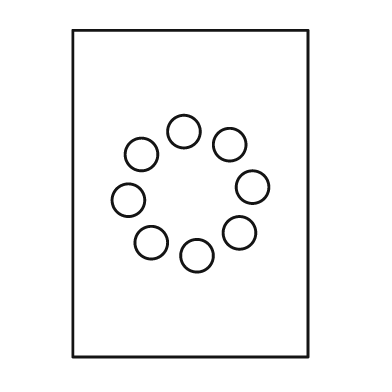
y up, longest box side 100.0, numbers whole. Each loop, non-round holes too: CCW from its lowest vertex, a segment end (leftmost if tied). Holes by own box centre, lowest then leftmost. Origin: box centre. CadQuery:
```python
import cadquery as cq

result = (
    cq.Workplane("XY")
    .moveTo(-36.0, -50.0)
    .lineTo(36.0, -50.0)
    .lineTo(36.0, 50.0)
    .lineTo(-36.0, 50.0)
    .close()
    .moveTo(2.0, -19.0)
    .circle(5.0)
    .moveTo(-12.0, -15.0)
    .circle(5.0)
    .moveTo(15.0, -12.0)
    .circle(5.0)
    .moveTo(-19.0, -2.0)
    .circle(5.0)
    .moveTo(19.0, 2.0)
    .circle(5.0)
    .moveTo(-15.0, 12.0)
    .circle(5.0)
    .moveTo(12.0, 15.0)
    .circle(5.0)
    .moveTo(-2.0, 19.0)
    .circle(5.0)
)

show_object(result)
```